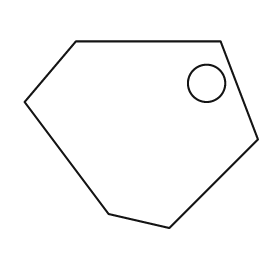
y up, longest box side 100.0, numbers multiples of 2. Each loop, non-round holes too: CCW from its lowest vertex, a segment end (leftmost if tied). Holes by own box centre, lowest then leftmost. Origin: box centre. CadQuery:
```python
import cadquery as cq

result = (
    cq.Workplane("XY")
    .moveTo(12.0, -40.0)
    .lineTo(50.0, -2.0)
    .lineTo(34.0, 40.0)
    .lineTo(-28.0, 40.0)
    .lineTo(-50.0, 14.0)
    .lineTo(-14.0, -34.0)
    .close()
    .moveTo(28.0, 22.0)
    .circle(8.0)
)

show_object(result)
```